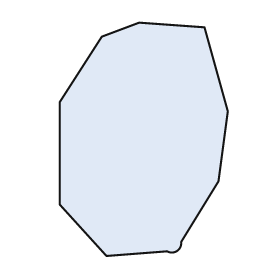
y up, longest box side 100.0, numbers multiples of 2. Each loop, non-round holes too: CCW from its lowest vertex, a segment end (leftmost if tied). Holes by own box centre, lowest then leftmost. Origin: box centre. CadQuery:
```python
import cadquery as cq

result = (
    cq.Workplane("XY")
    .moveTo(-16.0, -50.0)
    .lineTo(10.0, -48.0)
    .threePointArc((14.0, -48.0), (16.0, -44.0))
    .lineTo(32.0, -18.0)
    .lineTo(36.0, 12.0)
    .lineTo(26.0, 48.0)
    .lineTo(-2.0, 50.0)
    .lineTo(-18.0, 44.0)
    .lineTo(-36.0, 16.0)
    .lineTo(-36.0, -28.0)
    .close()
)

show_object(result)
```